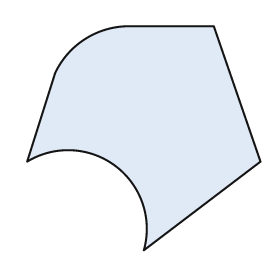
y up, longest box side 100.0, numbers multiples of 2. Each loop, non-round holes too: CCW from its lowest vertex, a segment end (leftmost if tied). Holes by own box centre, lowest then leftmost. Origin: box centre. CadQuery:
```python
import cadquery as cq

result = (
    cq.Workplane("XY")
    .moveTo(0.0, -48.0)
    .lineTo(50.0, -10.0)
    .lineTo(30.0, 48.0)
    .lineTo(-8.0, 48.0)
    .threePointArc((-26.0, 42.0), (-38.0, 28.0))
    .lineTo(-50.0, -10.0)
    .threePointArc((-12.0, -12.0), (0.0, -48.0))
    .close()
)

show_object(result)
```